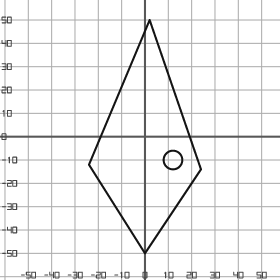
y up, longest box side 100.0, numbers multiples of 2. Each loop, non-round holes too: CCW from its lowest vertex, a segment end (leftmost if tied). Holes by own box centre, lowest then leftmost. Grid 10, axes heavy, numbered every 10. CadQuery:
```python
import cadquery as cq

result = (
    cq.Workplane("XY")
    .moveTo(0.0, -50.0)
    .lineTo(24.0, -14.0)
    .lineTo(2.0, 50.0)
    .lineTo(-24.0, -12.0)
    .close()
    .moveTo(12.0, -10.0)
    .circle(4.0)
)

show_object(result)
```